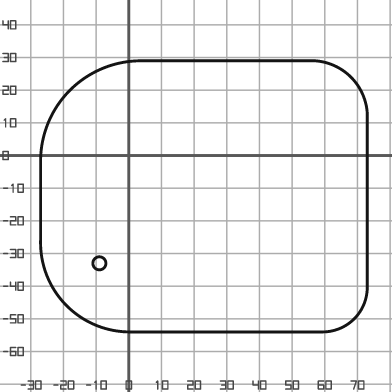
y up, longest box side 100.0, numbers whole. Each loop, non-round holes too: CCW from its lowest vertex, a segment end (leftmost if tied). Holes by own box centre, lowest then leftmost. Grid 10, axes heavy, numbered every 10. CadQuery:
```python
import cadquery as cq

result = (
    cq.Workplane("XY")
    .moveTo(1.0, -54.0)
    .lineTo(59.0, -54.0)
    .threePointArc((69.0, -50.0), (73.0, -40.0))
    .lineTo(73.0, 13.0)
    .threePointArc((68.0, 24.0), (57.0, 29.0))
    .lineTo(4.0, 29.0)
    .threePointArc((-18.0, 20.0), (-27.0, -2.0))
    .lineTo(-27.0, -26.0)
    .threePointArc((-19.0, -46.0), (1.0, -54.0))
    .close()
    .moveTo(-9.0, -33.0)
    .circle(2.0)
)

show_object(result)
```